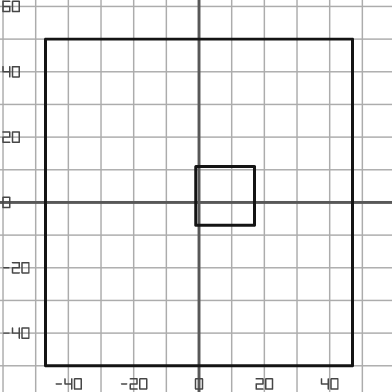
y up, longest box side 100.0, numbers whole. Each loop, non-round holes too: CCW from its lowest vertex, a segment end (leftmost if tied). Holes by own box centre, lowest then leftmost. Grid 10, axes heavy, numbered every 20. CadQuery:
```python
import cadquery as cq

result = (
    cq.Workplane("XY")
    .moveTo(-47.0, -50.0)
    .lineTo(47.0, -50.0)
    .lineTo(47.0, 50.0)
    .lineTo(-47.0, 50.0)
    .close()
    .moveTo(-1.0, -7.0)
    .lineTo(17.0, -7.0)
    .lineTo(17.0, 11.0)
    .lineTo(-1.0, 11.0)
    .close()
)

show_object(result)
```